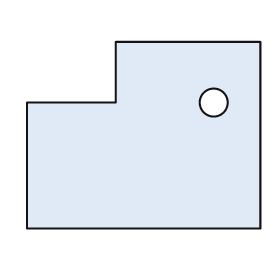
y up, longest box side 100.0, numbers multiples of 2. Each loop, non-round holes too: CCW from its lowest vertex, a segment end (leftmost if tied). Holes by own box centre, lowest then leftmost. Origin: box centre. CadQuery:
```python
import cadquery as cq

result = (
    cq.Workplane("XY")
    .moveTo(-50.0, -40.0)
    .lineTo(50.0, -40.0)
    .lineTo(50.0, 40.0)
    .lineTo(-12.0, 40.0)
    .lineTo(-12.0, 14.0)
    .lineTo(-50.0, 14.0)
    .close()
    .moveTo(30.0, 14.0)
    .circle(6.0)
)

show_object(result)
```